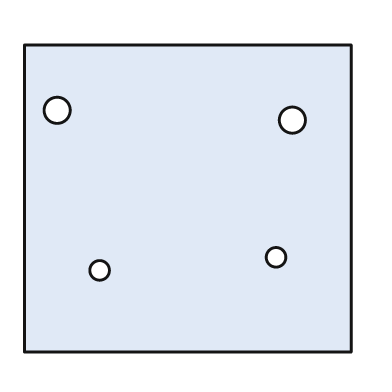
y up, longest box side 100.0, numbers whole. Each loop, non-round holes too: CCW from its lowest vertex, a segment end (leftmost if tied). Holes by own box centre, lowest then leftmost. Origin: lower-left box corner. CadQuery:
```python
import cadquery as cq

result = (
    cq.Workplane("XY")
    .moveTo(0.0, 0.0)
    .lineTo(100.0, 0.0)
    .lineTo(100.0, 94.0)
    .lineTo(0.0, 94.0)
    .close()
    .moveTo(23.0, 25.0)
    .circle(3.0)
    .moveTo(77.0, 29.0)
    .circle(3.0)
    .moveTo(82.0, 71.0)
    .circle(4.0)
    .moveTo(10.0, 74.0)
    .circle(4.0)
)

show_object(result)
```